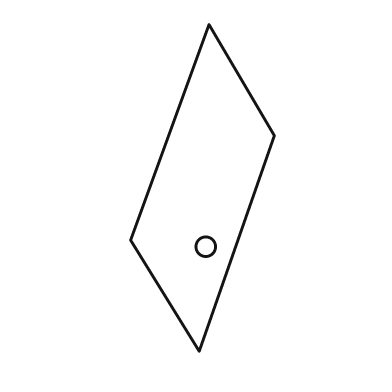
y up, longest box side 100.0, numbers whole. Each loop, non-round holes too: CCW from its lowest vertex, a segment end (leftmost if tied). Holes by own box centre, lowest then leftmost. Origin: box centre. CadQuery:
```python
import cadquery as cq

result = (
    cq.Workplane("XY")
    .moveTo(-1.0, -50.0)
    .lineTo(22.0, 16.0)
    .lineTo(2.0, 50.0)
    .lineTo(-22.0, -16.0)
    .close()
    .moveTo(1.0, -18.0)
    .circle(3.0)
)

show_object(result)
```